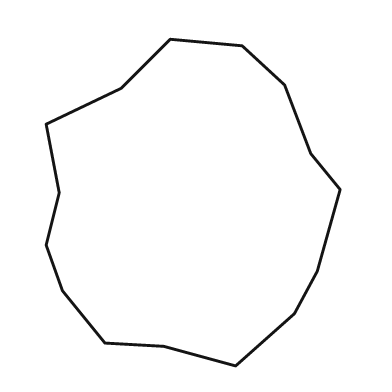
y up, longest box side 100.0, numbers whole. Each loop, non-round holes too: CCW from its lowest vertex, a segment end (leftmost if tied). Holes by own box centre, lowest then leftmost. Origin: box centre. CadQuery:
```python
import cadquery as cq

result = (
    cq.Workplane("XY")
    .moveTo(13.0, -50.0)
    .lineTo(31.0, -34.0)
    .lineTo(38.0, -21.0)
    .lineTo(45.0, 4.0)
    .lineTo(36.0, 15.0)
    .lineTo(28.0, 36.0)
    .lineTo(15.0, 48.0)
    .lineTo(-7.0, 50.0)
    .lineTo(-22.0, 35.0)
    .lineTo(-45.0, 24.0)
    .lineTo(-41.0, 3.0)
    .lineTo(-45.0, -13.0)
    .lineTo(-40.0, -27.0)
    .lineTo(-27.0, -43.0)
    .lineTo(-9.0, -44.0)
    .close()
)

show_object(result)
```